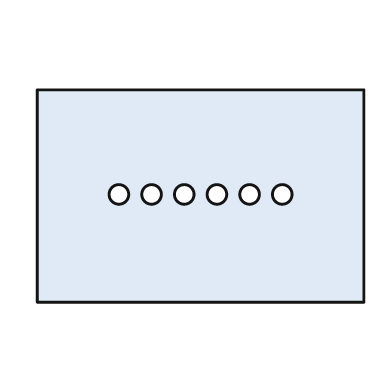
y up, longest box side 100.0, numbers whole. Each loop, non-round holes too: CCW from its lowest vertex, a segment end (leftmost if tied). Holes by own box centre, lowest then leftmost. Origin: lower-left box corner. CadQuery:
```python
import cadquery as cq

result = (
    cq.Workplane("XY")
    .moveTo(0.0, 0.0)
    .lineTo(100.0, 0.0)
    .lineTo(100.0, 65.0)
    .lineTo(0.0, 65.0)
    .close()
    .moveTo(25.0, 33.0)
    .circle(3.0)
    .moveTo(35.0, 33.0)
    .circle(3.0)
    .moveTo(45.0, 33.0)
    .circle(3.0)
    .moveTo(55.0, 33.0)
    .circle(3.0)
    .moveTo(65.0, 33.0)
    .circle(3.0)
    .moveTo(75.0, 33.0)
    .circle(3.0)
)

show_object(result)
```